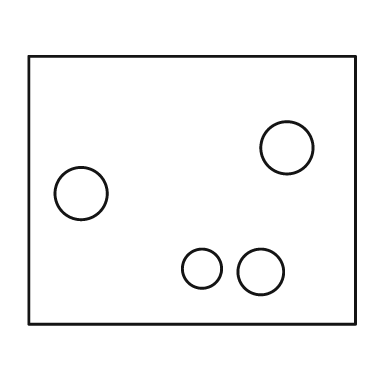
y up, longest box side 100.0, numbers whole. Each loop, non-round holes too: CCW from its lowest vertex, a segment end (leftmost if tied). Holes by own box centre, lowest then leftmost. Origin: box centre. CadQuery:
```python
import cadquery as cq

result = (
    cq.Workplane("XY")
    .moveTo(-50.0, -41.0)
    .lineTo(50.0, -41.0)
    .lineTo(50.0, 41.0)
    .lineTo(-50.0, 41.0)
    .close()
    .moveTo(21.0, -25.0)
    .circle(7.0)
    .moveTo(3.0, -24.0)
    .circle(6.0)
    .moveTo(-34.0, -1.0)
    .circle(8.0)
    .moveTo(29.0, 13.0)
    .circle(8.0)
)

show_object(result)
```